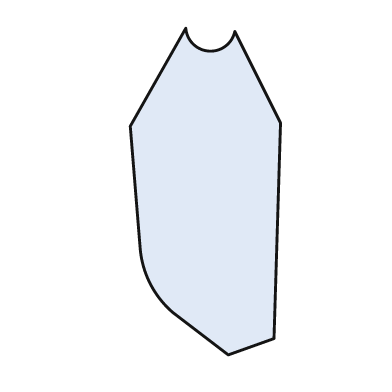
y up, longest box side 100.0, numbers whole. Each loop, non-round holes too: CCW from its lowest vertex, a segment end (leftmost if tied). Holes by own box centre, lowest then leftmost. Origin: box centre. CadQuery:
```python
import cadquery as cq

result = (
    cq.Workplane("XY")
    .moveTo(7.0, -50.0)
    .lineTo(21.0, -45.0)
    .lineTo(23.0, 21.0)
    .lineTo(9.0, 49.0)
    .threePointArc((1.0, 43.0), (-6.0, 50.0))
    .lineTo(-23.0, 20.0)
    .lineTo(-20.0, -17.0)
    .threePointArc((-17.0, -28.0), (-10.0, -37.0))
    .close()
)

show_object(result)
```